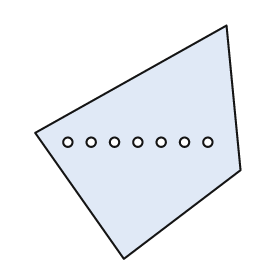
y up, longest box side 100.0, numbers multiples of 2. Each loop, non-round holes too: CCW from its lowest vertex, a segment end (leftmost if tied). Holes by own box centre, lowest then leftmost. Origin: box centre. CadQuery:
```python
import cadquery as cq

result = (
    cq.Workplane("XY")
    .moveTo(-6.0, -50.0)
    .lineTo(44.0, -12.0)
    .lineTo(38.0, 50.0)
    .lineTo(-44.0, 4.0)
    .close()
    .moveTo(-30.0, 0.0)
    .circle(2.0)
    .moveTo(-20.0, 0.0)
    .circle(2.0)
    .moveTo(-10.0, 0.0)
    .circle(2.0)
    .moveTo(0.0, 0.0)
    .circle(2.0)
    .moveTo(10.0, 0.0)
    .circle(2.0)
    .moveTo(20.0, 0.0)
    .circle(2.0)
    .moveTo(30.0, 0.0)
    .circle(2.0)
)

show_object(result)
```